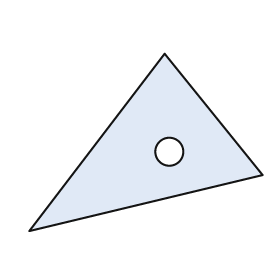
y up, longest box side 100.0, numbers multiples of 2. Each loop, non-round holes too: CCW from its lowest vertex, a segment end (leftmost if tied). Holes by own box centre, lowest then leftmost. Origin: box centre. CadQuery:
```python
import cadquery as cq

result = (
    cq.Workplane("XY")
    .moveTo(-50.0, -38.0)
    .lineTo(50.0, -14.0)
    .lineTo(8.0, 38.0)
    .close()
    .moveTo(10.0, -4.0)
    .circle(6.0)
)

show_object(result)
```